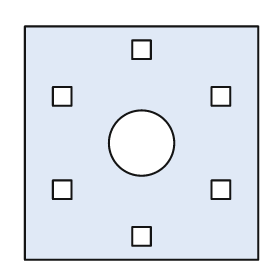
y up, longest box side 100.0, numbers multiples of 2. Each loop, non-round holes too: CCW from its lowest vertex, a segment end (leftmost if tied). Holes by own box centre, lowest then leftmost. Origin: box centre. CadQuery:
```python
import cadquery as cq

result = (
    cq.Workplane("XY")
    .moveTo(-50.0, -50.0)
    .lineTo(50.0, -50.0)
    .lineTo(50.0, 50.0)
    .lineTo(-50.0, 50.0)
    .close()
    .moveTo(-4.0, -44.0)
    .lineTo(4.0, -44.0)
    .lineTo(4.0, -36.0)
    .lineTo(-4.0, -36.0)
    .close()
    .moveTo(-38.0, -24.0)
    .lineTo(-30.0, -24.0)
    .lineTo(-30.0, -16.0)
    .lineTo(-38.0, -16.0)
    .close()
    .moveTo(30.0, -24.0)
    .lineTo(38.0, -24.0)
    .lineTo(38.0, -16.0)
    .lineTo(30.0, -16.0)
    .close()
    .moveTo(0.0, 0.0)
    .circle(14.0)
    .moveTo(-38.0, 16.0)
    .lineTo(-30.0, 16.0)
    .lineTo(-30.0, 24.0)
    .lineTo(-38.0, 24.0)
    .close()
    .moveTo(30.0, 16.0)
    .lineTo(38.0, 16.0)
    .lineTo(38.0, 24.0)
    .lineTo(30.0, 24.0)
    .close()
    .moveTo(-4.0, 36.0)
    .lineTo(4.0, 36.0)
    .lineTo(4.0, 44.0)
    .lineTo(-4.0, 44.0)
    .close()
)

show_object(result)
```